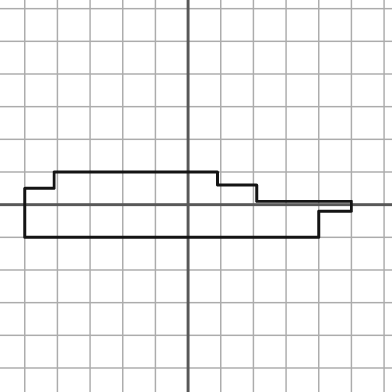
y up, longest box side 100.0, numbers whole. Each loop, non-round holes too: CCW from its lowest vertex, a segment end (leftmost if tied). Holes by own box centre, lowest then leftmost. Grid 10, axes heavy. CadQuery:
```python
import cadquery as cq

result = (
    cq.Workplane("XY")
    .moveTo(-50.0, -10.0)
    .lineTo(40.0, -10.0)
    .lineTo(40.0, -2.0)
    .lineTo(50.0, -2.0)
    .lineTo(50.0, 1.0)
    .lineTo(21.0, 1.0)
    .lineTo(21.0, 6.0)
    .lineTo(9.0, 6.0)
    .lineTo(9.0, 10.0)
    .lineTo(-41.0, 10.0)
    .lineTo(-41.0, 5.0)
    .lineTo(-50.0, 5.0)
    .close()
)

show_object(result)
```